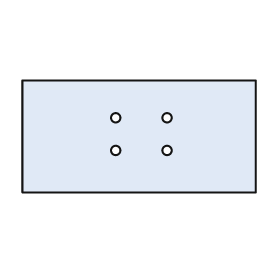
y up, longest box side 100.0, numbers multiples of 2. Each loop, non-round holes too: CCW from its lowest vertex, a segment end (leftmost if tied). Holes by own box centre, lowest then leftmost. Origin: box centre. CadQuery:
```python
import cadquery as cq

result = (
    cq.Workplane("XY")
    .moveTo(-50.0, -24.0)
    .lineTo(50.0, -24.0)
    .lineTo(50.0, 24.0)
    .lineTo(-50.0, 24.0)
    .close()
    .moveTo(-10.0, -6.0)
    .circle(2.0)
    .moveTo(12.0, -6.0)
    .circle(2.0)
    .moveTo(-10.0, 8.0)
    .circle(2.0)
    .moveTo(12.0, 8.0)
    .circle(2.0)
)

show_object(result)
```